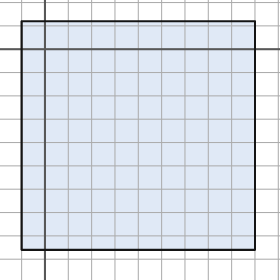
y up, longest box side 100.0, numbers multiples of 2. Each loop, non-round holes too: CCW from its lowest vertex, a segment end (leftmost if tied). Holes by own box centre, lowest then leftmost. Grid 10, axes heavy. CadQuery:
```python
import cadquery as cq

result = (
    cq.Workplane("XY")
    .moveTo(-10.0, -86.0)
    .lineTo(90.0, -86.0)
    .lineTo(90.0, 12.0)
    .lineTo(-10.0, 12.0)
    .close()
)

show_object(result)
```